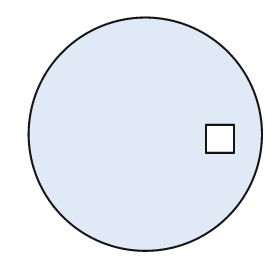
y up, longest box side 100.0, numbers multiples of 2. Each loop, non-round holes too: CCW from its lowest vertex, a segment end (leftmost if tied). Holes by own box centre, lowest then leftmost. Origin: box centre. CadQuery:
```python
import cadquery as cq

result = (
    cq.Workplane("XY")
    .moveTo(0.0, 0.0)
    .circle(50.0)
    .moveTo(26.0, -8.0)
    .lineTo(38.0, -8.0)
    .lineTo(38.0, 4.0)
    .lineTo(26.0, 4.0)
    .close()
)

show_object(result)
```